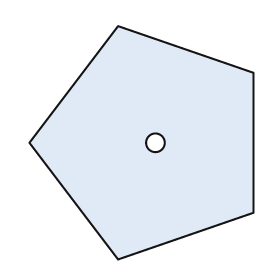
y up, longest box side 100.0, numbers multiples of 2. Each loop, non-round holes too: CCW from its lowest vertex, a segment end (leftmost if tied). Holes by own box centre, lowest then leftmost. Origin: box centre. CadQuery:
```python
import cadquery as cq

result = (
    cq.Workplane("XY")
    .moveTo(-10.0, -50.0)
    .lineTo(48.0, -30.0)
    .lineTo(48.0, 30.0)
    .lineTo(-10.0, 50.0)
    .lineTo(-48.0, 0.0)
    .close()
    .moveTo(6.0, 0.0)
    .circle(4.0)
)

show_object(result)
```